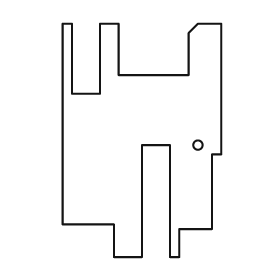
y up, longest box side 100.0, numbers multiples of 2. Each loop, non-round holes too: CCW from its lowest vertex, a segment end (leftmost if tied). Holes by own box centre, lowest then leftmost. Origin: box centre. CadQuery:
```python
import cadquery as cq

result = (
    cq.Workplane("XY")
    .moveTo(-12.0, -50.0)
    .lineTo(0.0, -50.0)
    .lineTo(0.0, -2.0)
    .lineTo(12.0, -2.0)
    .lineTo(12.0, -50.0)
    .lineTo(16.0, -50.0)
    .lineTo(16.0, -38.0)
    .lineTo(30.0, -38.0)
    .lineTo(30.0, -6.0)
    .lineTo(34.0, -6.0)
    .lineTo(34.0, 50.0)
    .lineTo(24.0, 50.0)
    .lineTo(20.0, 46.0)
    .lineTo(20.0, 28.0)
    .lineTo(-10.0, 28.0)
    .lineTo(-10.0, 50.0)
    .lineTo(-18.0, 50.0)
    .lineTo(-18.0, 20.0)
    .lineTo(-30.0, 20.0)
    .lineTo(-30.0, 50.0)
    .lineTo(-34.0, 50.0)
    .lineTo(-34.0, -36.0)
    .lineTo(-12.0, -36.0)
    .close()
    .moveTo(24.0, -2.0)
    .circle(2.0)
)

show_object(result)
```